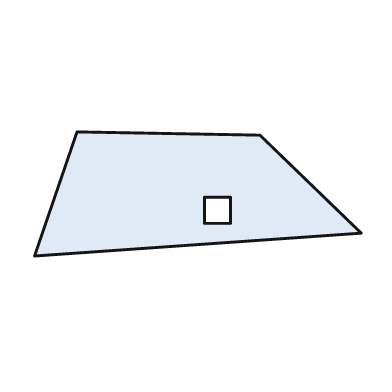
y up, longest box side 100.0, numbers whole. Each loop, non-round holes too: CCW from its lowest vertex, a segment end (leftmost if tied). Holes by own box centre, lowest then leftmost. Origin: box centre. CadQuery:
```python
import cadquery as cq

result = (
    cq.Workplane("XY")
    .moveTo(-50.0, -19.0)
    .lineTo(50.0, -12.0)
    .lineTo(19.0, 18.0)
    .lineTo(-37.0, 19.0)
    .close()
    .moveTo(2.0, -9.0)
    .lineTo(10.0, -9.0)
    .lineTo(10.0, -1.0)
    .lineTo(2.0, -1.0)
    .close()
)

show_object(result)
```